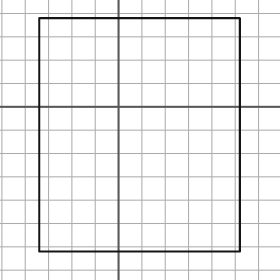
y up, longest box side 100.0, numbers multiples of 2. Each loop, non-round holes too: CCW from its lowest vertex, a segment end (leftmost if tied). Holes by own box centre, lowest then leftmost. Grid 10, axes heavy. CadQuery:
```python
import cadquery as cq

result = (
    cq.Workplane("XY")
    .moveTo(-34.0, -62.0)
    .lineTo(52.0, -62.0)
    .lineTo(52.0, 38.0)
    .lineTo(-34.0, 38.0)
    .close()
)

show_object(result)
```